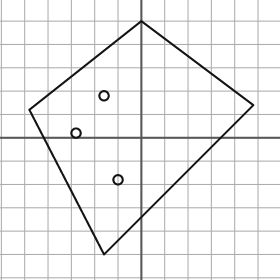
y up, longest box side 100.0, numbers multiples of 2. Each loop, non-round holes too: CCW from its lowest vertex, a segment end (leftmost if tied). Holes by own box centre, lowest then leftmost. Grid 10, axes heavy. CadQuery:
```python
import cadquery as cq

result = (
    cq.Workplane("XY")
    .moveTo(-16.0, -50.0)
    .lineTo(48.0, 14.0)
    .lineTo(0.0, 50.0)
    .lineTo(-48.0, 12.0)
    .close()
    .moveTo(-10.0, -18.0)
    .circle(2.0)
    .moveTo(-28.0, 2.0)
    .circle(2.0)
    .moveTo(-16.0, 18.0)
    .circle(2.0)
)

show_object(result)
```